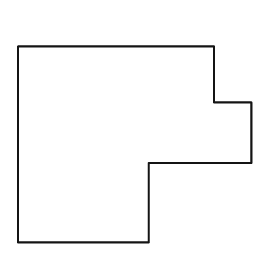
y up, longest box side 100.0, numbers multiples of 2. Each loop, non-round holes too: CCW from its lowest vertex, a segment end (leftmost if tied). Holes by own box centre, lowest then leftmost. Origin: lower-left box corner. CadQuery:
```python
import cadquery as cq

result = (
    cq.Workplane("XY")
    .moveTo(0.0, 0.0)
    .lineTo(56.0, 0.0)
    .lineTo(56.0, 34.0)
    .lineTo(100.0, 34.0)
    .lineTo(100.0, 60.0)
    .lineTo(84.0, 60.0)
    .lineTo(84.0, 84.0)
    .lineTo(0.0, 84.0)
    .close()
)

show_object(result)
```